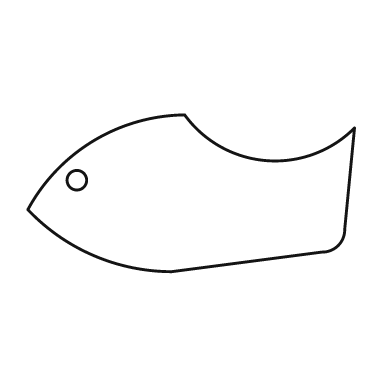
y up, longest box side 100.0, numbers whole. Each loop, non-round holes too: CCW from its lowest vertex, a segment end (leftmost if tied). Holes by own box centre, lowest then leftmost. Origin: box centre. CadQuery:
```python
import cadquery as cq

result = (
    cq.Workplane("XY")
    .moveTo(-6.0, -24.0)
    .lineTo(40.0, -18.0)
    .threePointArc((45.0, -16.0), (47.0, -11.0))
    .lineTo(50.0, 20.0)
    .threePointArc((23.0, 10.0), (-2.0, 24.0))
    .threePointArc((-30.0, 16.0), (-50.0, -5.0))
    .threePointArc((-30.0, -19.0), (-6.0, -24.0))
    .close()
    .moveTo(-35.0, 4.0)
    .circle(3.0)
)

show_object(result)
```